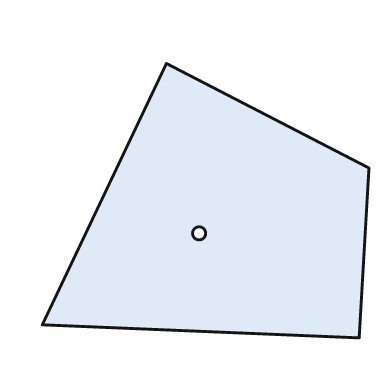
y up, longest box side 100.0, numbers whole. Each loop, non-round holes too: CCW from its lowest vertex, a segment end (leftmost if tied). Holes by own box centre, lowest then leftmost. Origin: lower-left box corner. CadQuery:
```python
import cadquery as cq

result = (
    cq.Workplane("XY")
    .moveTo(97.0, 0.0)
    .lineTo(100.0, 52.0)
    .lineTo(38.0, 84.0)
    .lineTo(0.0, 4.0)
    .close()
    .moveTo(48.0, 32.0)
    .circle(2.0)
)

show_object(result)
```